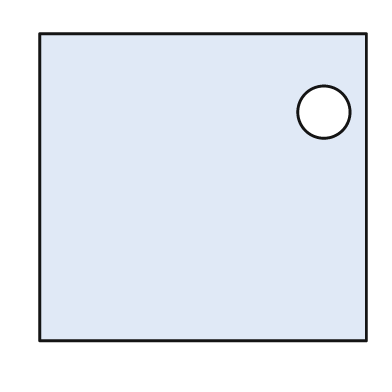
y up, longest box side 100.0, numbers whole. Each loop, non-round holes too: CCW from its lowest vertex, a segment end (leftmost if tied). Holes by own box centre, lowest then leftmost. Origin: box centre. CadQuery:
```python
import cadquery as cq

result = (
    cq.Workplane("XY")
    .moveTo(-50.0, -47.0)
    .lineTo(50.0, -47.0)
    .lineTo(50.0, 47.0)
    .lineTo(-50.0, 47.0)
    .close()
    .moveTo(37.0, 23.0)
    .circle(8.0)
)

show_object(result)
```